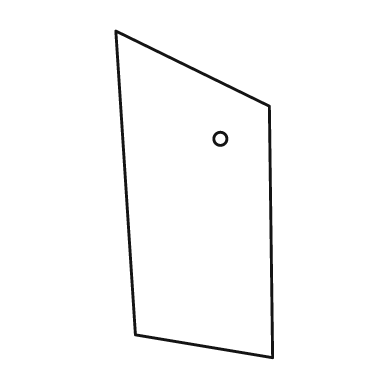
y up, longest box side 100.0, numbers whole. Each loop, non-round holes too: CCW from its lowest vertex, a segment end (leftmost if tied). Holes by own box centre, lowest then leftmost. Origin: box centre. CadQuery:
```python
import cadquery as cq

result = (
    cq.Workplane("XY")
    .moveTo(24.0, -50.0)
    .lineTo(23.0, 27.0)
    .lineTo(-24.0, 50.0)
    .lineTo(-18.0, -43.0)
    .close()
    .moveTo(8.0, 17.0)
    .circle(2.0)
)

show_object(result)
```